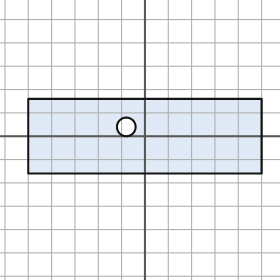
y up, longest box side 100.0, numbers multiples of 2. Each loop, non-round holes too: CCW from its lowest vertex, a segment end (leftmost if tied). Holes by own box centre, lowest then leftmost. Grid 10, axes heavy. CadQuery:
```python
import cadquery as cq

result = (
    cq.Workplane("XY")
    .moveTo(-50.0, -16.0)
    .lineTo(50.0, -16.0)
    .lineTo(50.0, 16.0)
    .lineTo(-50.0, 16.0)
    .close()
    .moveTo(-8.0, 4.0)
    .circle(4.0)
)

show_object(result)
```